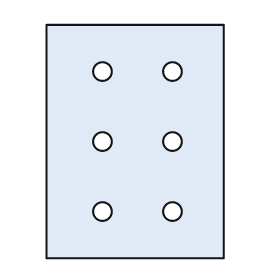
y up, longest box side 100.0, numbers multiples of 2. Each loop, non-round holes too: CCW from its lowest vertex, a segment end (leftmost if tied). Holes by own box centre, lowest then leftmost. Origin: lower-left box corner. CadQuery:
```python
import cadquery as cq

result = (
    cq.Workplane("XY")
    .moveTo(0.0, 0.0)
    .lineTo(76.0, 0.0)
    .lineTo(76.0, 100.0)
    .lineTo(0.0, 100.0)
    .close()
    .moveTo(24.0, 20.0)
    .circle(4.0)
    .moveTo(54.0, 20.0)
    .circle(4.0)
    .moveTo(24.0, 50.0)
    .circle(4.0)
    .moveTo(54.0, 50.0)
    .circle(4.0)
    .moveTo(24.0, 80.0)
    .circle(4.0)
    .moveTo(54.0, 80.0)
    .circle(4.0)
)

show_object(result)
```